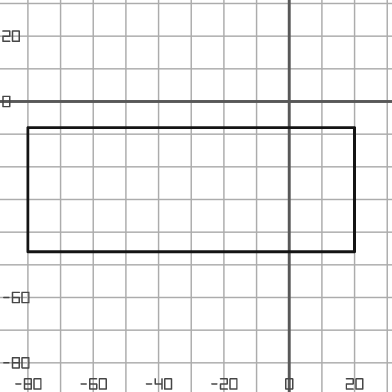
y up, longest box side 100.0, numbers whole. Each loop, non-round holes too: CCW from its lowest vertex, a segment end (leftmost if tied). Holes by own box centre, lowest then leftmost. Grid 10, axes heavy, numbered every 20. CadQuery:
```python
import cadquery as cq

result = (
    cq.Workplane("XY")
    .moveTo(-80.0, -46.0)
    .lineTo(20.0, -46.0)
    .lineTo(20.0, -8.0)
    .lineTo(-80.0, -8.0)
    .close()
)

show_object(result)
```